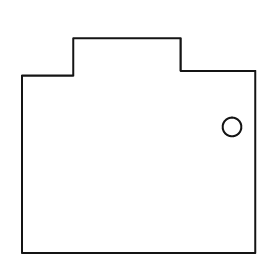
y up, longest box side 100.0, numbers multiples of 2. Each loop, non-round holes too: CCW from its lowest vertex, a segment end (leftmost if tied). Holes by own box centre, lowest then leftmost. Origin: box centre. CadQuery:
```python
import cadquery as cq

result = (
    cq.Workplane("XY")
    .moveTo(-50.0, -46.0)
    .lineTo(50.0, -46.0)
    .lineTo(50.0, 32.0)
    .lineTo(18.0, 32.0)
    .lineTo(18.0, 46.0)
    .lineTo(-28.0, 46.0)
    .lineTo(-28.0, 30.0)
    .lineTo(-50.0, 30.0)
    .close()
    .moveTo(40.0, 8.0)
    .circle(4.0)
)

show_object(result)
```